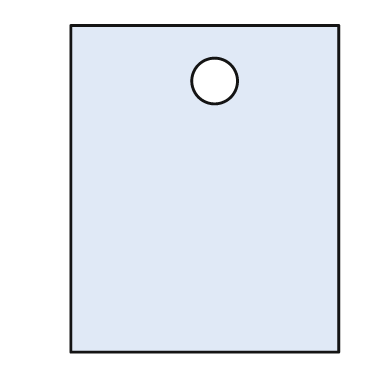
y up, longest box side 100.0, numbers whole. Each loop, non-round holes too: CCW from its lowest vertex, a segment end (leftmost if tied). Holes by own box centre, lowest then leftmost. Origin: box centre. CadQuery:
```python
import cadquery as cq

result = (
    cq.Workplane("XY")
    .moveTo(-41.0, -50.0)
    .lineTo(41.0, -50.0)
    .lineTo(41.0, 50.0)
    .lineTo(-41.0, 50.0)
    .close()
    .moveTo(3.0, 33.0)
    .circle(7.0)
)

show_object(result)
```